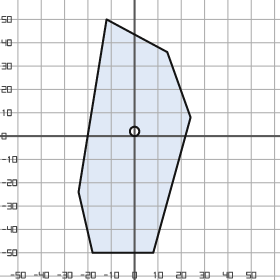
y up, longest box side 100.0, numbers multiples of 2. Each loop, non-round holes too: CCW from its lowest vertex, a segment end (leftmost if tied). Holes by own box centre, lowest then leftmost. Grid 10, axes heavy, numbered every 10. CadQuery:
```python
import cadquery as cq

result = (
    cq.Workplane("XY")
    .moveTo(-18.0, -50.0)
    .lineTo(8.0, -50.0)
    .lineTo(24.0, 8.0)
    .lineTo(14.0, 36.0)
    .lineTo(-12.0, 50.0)
    .lineTo(-24.0, -24.0)
    .close()
    .moveTo(0.0, 2.0)
    .circle(2.0)
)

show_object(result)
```